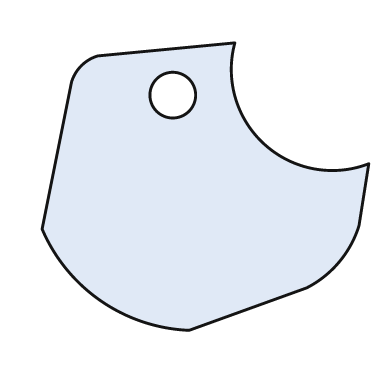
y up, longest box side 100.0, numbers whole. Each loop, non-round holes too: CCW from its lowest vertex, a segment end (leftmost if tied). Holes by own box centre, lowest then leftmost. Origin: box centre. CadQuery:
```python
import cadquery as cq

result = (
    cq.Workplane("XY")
    .moveTo(-5.0, -44.0)
    .lineTo(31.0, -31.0)
    .threePointArc((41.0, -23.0), (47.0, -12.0))
    .lineTo(50.0, 7.0)
    .threePointArc((18.0, 13.0), (9.0, 44.0))
    .lineTo(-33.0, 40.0)
    .threePointArc((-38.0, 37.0), (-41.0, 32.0))
    .lineTo(-50.0, -13.0)
    .threePointArc((-32.0, -35.0), (-5.0, -44.0))
    .close()
    .moveTo(-10.0, 28.0)
    .circle(7.0)
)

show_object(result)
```